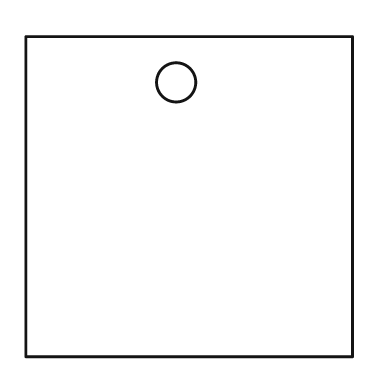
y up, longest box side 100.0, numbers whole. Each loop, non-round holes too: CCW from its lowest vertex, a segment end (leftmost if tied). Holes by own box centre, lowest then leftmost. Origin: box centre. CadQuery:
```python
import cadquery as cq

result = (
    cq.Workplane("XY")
    .moveTo(-50.0, -49.0)
    .lineTo(50.0, -49.0)
    .lineTo(50.0, 49.0)
    .lineTo(-50.0, 49.0)
    .close()
    .moveTo(-4.0, 35.0)
    .circle(6.0)
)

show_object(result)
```